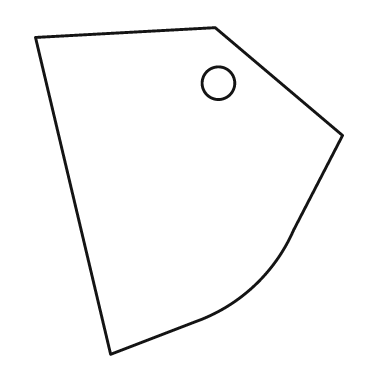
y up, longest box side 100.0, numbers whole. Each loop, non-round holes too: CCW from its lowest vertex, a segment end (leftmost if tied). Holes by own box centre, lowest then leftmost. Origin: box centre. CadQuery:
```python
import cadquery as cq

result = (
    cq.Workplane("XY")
    .moveTo(-24.0, -50.0)
    .lineTo(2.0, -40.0)
    .threePointArc((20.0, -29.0), (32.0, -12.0))
    .lineTo(47.0, 17.0)
    .lineTo(8.0, 50.0)
    .lineTo(-47.0, 47.0)
    .close()
    .moveTo(9.0, 33.0)
    .circle(5.0)
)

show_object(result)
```